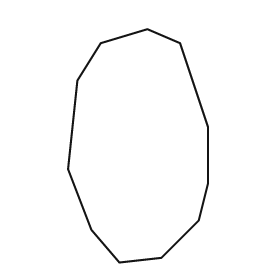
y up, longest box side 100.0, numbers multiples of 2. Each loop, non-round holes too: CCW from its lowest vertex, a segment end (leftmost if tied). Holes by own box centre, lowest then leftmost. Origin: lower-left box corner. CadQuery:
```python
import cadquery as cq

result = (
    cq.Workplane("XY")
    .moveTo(22.0, 0.0)
    .lineTo(40.0, 2.0)
    .lineTo(56.0, 18.0)
    .lineTo(60.0, 34.0)
    .lineTo(60.0, 58.0)
    .lineTo(48.0, 94.0)
    .lineTo(34.0, 100.0)
    .lineTo(14.0, 94.0)
    .lineTo(4.0, 78.0)
    .lineTo(0.0, 40.0)
    .lineTo(10.0, 14.0)
    .close()
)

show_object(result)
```